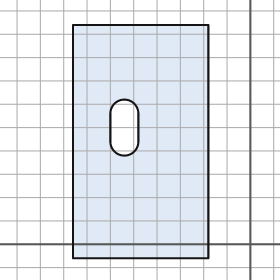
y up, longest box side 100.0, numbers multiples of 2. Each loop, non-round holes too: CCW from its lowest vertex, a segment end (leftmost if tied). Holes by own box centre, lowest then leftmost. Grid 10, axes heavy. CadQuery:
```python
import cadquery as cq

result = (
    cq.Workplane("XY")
    .moveTo(-76.0, -6.0)
    .lineTo(-18.0, -6.0)
    .lineTo(-18.0, 94.0)
    .lineTo(-76.0, 94.0)
    .close()
    .moveTo(-60.0, 44.0)
    .threePointArc((-54.0, 38.0), (-48.0, 44.0))
    .lineTo(-48.0, 56.0)
    .threePointArc((-54.0, 62.0), (-60.0, 56.0))
    .close()
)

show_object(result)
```